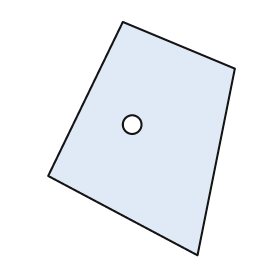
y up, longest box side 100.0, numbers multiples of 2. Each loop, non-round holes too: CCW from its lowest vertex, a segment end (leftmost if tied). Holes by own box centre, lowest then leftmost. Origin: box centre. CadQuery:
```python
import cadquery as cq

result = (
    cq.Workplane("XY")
    .moveTo(24.0, -50.0)
    .lineTo(40.0, 30.0)
    .lineTo(-8.0, 50.0)
    .lineTo(-40.0, -16.0)
    .close()
    .moveTo(-4.0, 6.0)
    .circle(4.0)
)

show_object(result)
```